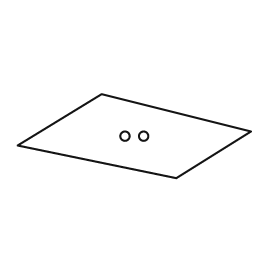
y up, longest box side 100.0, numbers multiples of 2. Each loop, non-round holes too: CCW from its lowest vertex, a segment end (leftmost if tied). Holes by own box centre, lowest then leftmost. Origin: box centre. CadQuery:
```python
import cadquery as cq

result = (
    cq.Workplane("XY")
    .moveTo(18.0, -18.0)
    .lineTo(50.0, 2.0)
    .lineTo(-14.0, 18.0)
    .lineTo(-50.0, -4.0)
    .close()
    .moveTo(-4.0, 0.0)
    .circle(2.0)
    .moveTo(4.0, 0.0)
    .circle(2.0)
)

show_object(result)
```